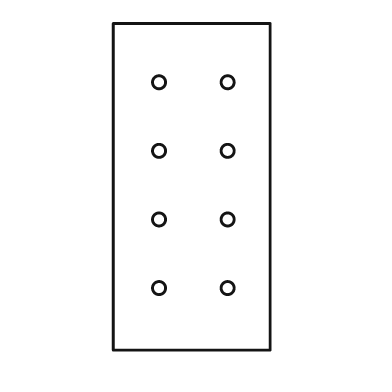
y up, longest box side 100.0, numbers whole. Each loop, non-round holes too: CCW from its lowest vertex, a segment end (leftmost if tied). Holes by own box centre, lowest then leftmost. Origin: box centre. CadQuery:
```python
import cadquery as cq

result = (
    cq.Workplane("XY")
    .moveTo(-24.0, -50.0)
    .lineTo(24.0, -50.0)
    .lineTo(24.0, 50.0)
    .lineTo(-24.0, 50.0)
    .close()
    .moveTo(-10.0, -31.0)
    .circle(2.0)
    .moveTo(11.0, -31.0)
    .circle(2.0)
    .moveTo(-10.0, -10.0)
    .circle(2.0)
    .moveTo(11.0, -10.0)
    .circle(2.0)
    .moveTo(-10.0, 11.0)
    .circle(2.0)
    .moveTo(11.0, 11.0)
    .circle(2.0)
    .moveTo(-10.0, 32.0)
    .circle(2.0)
    .moveTo(11.0, 32.0)
    .circle(2.0)
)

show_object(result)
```